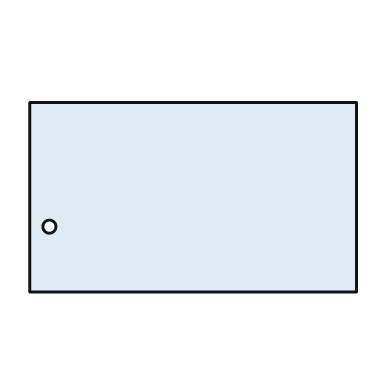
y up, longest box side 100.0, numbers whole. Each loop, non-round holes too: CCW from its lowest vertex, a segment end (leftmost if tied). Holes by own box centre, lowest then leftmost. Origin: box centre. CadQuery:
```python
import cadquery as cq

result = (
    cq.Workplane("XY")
    .moveTo(-50.0, -29.0)
    .lineTo(50.0, -29.0)
    .lineTo(50.0, 29.0)
    .lineTo(-50.0, 29.0)
    .close()
    .moveTo(-44.0, -9.0)
    .circle(2.0)
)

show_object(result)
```